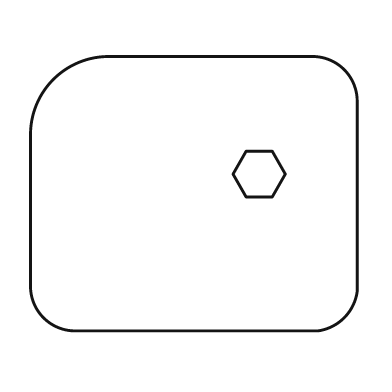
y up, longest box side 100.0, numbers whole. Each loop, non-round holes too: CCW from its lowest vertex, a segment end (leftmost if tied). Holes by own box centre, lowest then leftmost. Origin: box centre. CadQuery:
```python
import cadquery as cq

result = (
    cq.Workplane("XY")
    .moveTo(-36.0, -42.0)
    .lineTo(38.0, -42.0)
    .threePointArc((46.0, -38.0), (50.0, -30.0))
    .lineTo(50.0, 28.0)
    .threePointArc((46.0, 38.0), (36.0, 42.0))
    .lineTo(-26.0, 42.0)
    .threePointArc((-43.0, 35.0), (-50.0, 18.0))
    .lineTo(-50.0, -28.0)
    .threePointArc((-46.0, -38.0), (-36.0, -42.0))
    .close()
    .moveTo(16.0, -1.0)
    .lineTo(24.0, -1.0)
    .lineTo(28.0, 6.0)
    .lineTo(24.0, 13.0)
    .lineTo(16.0, 13.0)
    .lineTo(12.0, 6.0)
    .close()
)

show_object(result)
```